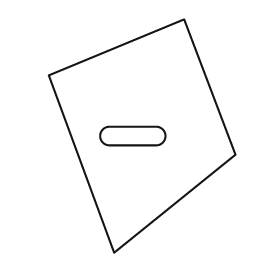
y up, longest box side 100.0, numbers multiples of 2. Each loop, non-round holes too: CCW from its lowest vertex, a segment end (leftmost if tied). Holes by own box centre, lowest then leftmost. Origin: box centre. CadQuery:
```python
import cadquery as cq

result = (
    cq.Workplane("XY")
    .moveTo(-12.0, -50.0)
    .lineTo(40.0, -8.0)
    .lineTo(18.0, 50.0)
    .lineTo(-40.0, 26.0)
    .close()
    .moveTo(-14.0, -4.0)
    .lineTo(6.0, -4.0)
    .threePointArc((10.0, 0.0), (6.0, 4.0))
    .lineTo(-14.0, 4.0)
    .threePointArc((-18.0, 0.0), (-14.0, -4.0))
    .close()
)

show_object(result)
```